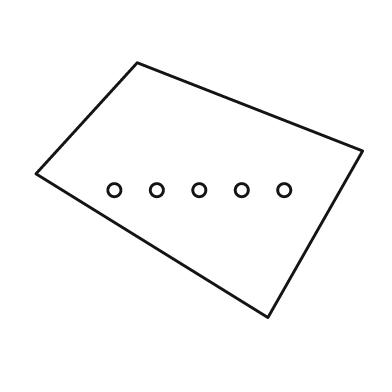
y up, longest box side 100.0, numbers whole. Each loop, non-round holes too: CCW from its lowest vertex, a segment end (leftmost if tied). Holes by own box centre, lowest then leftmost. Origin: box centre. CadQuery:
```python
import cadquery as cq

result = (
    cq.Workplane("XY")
    .moveTo(21.0, -39.0)
    .lineTo(50.0, 12.0)
    .lineTo(-19.0, 39.0)
    .lineTo(-50.0, 5.0)
    .close()
    .moveTo(-26.0, 0.0)
    .circle(2.0)
    .moveTo(-13.0, 0.0)
    .circle(2.0)
    .moveTo(0.0, 0.0)
    .circle(2.0)
    .moveTo(13.0, 0.0)
    .circle(2.0)
    .moveTo(26.0, 0.0)
    .circle(2.0)
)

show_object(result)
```